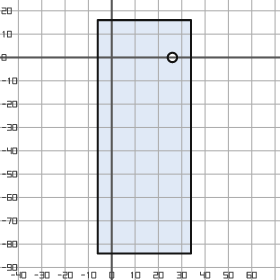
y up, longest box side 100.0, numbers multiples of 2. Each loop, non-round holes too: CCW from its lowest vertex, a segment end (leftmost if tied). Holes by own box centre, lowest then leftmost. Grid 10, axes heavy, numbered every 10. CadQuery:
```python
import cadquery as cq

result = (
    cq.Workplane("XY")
    .moveTo(-6.0, -84.0)
    .lineTo(34.0, -84.0)
    .lineTo(34.0, 16.0)
    .lineTo(-6.0, 16.0)
    .close()
    .moveTo(26.0, 0.0)
    .circle(2.0)
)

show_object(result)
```